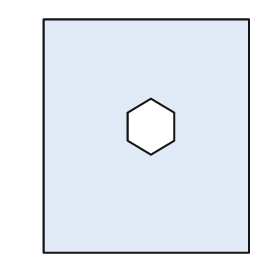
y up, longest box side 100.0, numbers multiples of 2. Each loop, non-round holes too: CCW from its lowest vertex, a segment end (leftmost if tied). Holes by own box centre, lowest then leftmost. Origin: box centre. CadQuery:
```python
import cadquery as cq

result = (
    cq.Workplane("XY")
    .moveTo(-44.0, -50.0)
    .lineTo(44.0, -50.0)
    .lineTo(44.0, 50.0)
    .lineTo(-44.0, 50.0)
    .close()
    .moveTo(2.0, -8.0)
    .lineTo(12.0, -2.0)
    .lineTo(12.0, 10.0)
    .lineTo(2.0, 16.0)
    .lineTo(-8.0, 10.0)
    .lineTo(-8.0, -2.0)
    .close()
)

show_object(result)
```